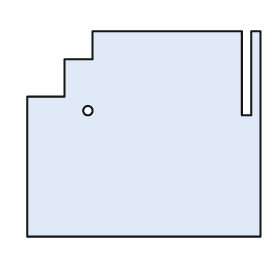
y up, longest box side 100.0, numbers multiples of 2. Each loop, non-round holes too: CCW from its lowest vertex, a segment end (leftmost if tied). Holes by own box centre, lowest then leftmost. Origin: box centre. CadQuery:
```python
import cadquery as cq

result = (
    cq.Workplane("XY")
    .moveTo(-50.0, -44.0)
    .lineTo(50.0, -44.0)
    .lineTo(50.0, 44.0)
    .lineTo(46.0, 44.0)
    .lineTo(46.0, 8.0)
    .lineTo(42.0, 8.0)
    .lineTo(42.0, 44.0)
    .lineTo(-22.0, 44.0)
    .lineTo(-22.0, 32.0)
    .lineTo(-34.0, 32.0)
    .lineTo(-34.0, 16.0)
    .lineTo(-50.0, 16.0)
    .close()
    .moveTo(-24.0, 10.0)
    .circle(2.0)
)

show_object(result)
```